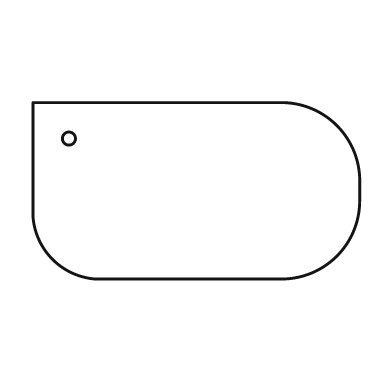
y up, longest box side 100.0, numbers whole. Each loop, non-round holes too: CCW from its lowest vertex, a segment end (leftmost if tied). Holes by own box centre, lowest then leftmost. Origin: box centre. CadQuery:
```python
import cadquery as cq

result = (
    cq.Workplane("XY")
    .moveTo(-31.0, -27.0)
    .lineTo(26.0, -27.0)
    .threePointArc((43.0, -20.0), (50.0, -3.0))
    .lineTo(50.0, 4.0)
    .threePointArc((43.0, 20.0), (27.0, 27.0))
    .lineTo(-50.0, 27.0)
    .lineTo(-50.0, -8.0)
    .threePointArc((-44.0, -21.0), (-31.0, -27.0))
    .close()
    .moveTo(-39.0, 16.0)
    .circle(2.0)
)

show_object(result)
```